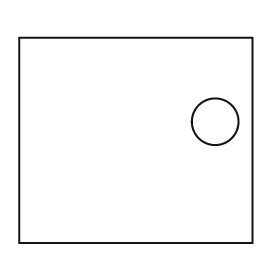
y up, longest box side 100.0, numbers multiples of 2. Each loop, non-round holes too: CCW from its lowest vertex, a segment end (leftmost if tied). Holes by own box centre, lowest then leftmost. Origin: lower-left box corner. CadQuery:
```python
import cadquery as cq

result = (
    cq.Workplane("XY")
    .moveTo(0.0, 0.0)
    .lineTo(100.0, 0.0)
    .lineTo(100.0, 88.0)
    .lineTo(0.0, 88.0)
    .close()
    .moveTo(84.0, 52.0)
    .circle(10.0)
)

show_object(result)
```